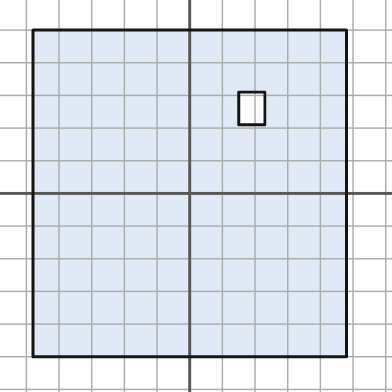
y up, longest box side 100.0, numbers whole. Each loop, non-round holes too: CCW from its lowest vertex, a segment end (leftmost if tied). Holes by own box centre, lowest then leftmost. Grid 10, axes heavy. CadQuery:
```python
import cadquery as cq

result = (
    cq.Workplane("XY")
    .moveTo(-48.0, -50.0)
    .lineTo(48.0, -50.0)
    .lineTo(48.0, 50.0)
    .lineTo(-48.0, 50.0)
    .close()
    .moveTo(15.0, 21.0)
    .lineTo(23.0, 21.0)
    .lineTo(23.0, 31.0)
    .lineTo(15.0, 31.0)
    .close()
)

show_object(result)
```